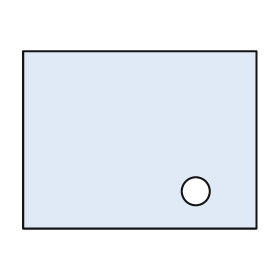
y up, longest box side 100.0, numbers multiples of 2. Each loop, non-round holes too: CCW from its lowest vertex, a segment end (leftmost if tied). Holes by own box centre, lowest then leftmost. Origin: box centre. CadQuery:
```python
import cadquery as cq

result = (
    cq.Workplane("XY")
    .moveTo(-50.0, -38.0)
    .lineTo(50.0, -38.0)
    .lineTo(50.0, 38.0)
    .lineTo(-50.0, 38.0)
    .close()
    .moveTo(24.0, -22.0)
    .circle(6.0)
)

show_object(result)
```